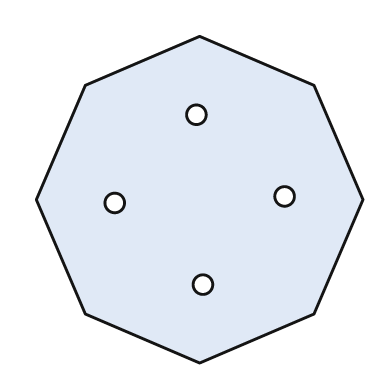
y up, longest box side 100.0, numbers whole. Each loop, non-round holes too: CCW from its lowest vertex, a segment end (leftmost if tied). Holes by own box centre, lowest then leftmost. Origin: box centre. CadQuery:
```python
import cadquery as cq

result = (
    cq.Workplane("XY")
    .moveTo(0.0, -50.0)
    .lineTo(35.0, -35.0)
    .lineTo(50.0, 0.0)
    .lineTo(35.0, 35.0)
    .lineTo(0.0, 50.0)
    .lineTo(-35.0, 35.0)
    .lineTo(-50.0, 0.0)
    .lineTo(-35.0, -35.0)
    .close()
    .moveTo(1.0, -26.0)
    .circle(3.0)
    .moveTo(-26.0, -1.0)
    .circle(3.0)
    .moveTo(26.0, 1.0)
    .circle(3.0)
    .moveTo(-1.0, 26.0)
    .circle(3.0)
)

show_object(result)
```